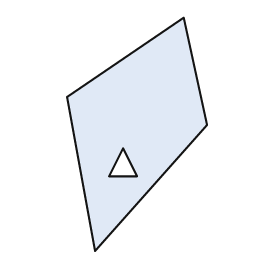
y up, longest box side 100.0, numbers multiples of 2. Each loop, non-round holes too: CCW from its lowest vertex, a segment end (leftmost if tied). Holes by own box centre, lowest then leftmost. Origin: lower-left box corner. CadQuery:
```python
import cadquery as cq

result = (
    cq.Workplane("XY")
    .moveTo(12.0, 0.0)
    .lineTo(60.0, 54.0)
    .lineTo(50.0, 100.0)
    .lineTo(0.0, 66.0)
    .close()
    .moveTo(18.0, 32.0)
    .lineTo(30.0, 32.0)
    .lineTo(24.0, 44.0)
    .close()
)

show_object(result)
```